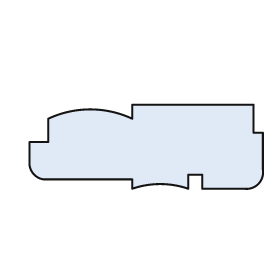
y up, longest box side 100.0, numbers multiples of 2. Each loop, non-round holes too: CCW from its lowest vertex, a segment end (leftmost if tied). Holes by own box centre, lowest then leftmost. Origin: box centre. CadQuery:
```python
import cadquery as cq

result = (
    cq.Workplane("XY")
    .moveTo(-6.0, -18.0)
    .threePointArc((6.0, -16.0), (18.0, -18.0))
    .lineTo(18.0, -12.0)
    .lineTo(24.0, -12.0)
    .lineTo(24.0, -18.0)
    .lineTo(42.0, -18.0)
    .threePointArc((48.0, -16.0), (50.0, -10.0))
    .lineTo(50.0, 6.0)
    .lineTo(46.0, 6.0)
    .lineTo(46.0, 18.0)
    .lineTo(-6.0, 18.0)
    .lineTo(-6.0, 12.0)
    .threePointArc((-24.0, 16.0), (-42.0, 12.0))
    .lineTo(-42.0, 2.0)
    .lineTo(-50.0, 2.0)
    .lineTo(-50.0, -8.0)
    .threePointArc((-48.0, -12.0), (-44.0, -14.0))
    .lineTo(-6.0, -14.0)
    .close()
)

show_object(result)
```